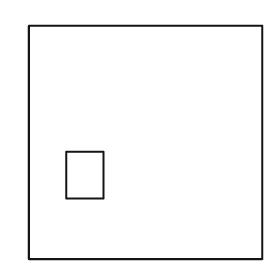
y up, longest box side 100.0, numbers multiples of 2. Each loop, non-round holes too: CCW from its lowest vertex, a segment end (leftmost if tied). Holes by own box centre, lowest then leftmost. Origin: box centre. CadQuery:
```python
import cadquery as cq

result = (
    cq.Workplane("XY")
    .moveTo(-50.0, -50.0)
    .lineTo(50.0, -50.0)
    .lineTo(50.0, 50.0)
    .lineTo(-50.0, 50.0)
    .close()
    .moveTo(-34.0, -24.0)
    .lineTo(-18.0, -24.0)
    .lineTo(-18.0, -4.0)
    .lineTo(-34.0, -4.0)
    .close()
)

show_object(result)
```